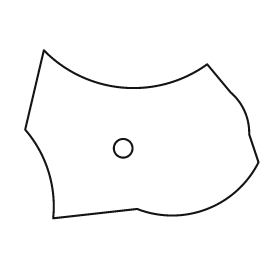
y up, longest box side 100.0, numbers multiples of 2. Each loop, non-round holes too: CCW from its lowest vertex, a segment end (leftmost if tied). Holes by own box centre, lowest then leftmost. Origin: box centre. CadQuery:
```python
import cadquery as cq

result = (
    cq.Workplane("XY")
    .moveTo(-38.0, -36.0)
    .lineTo(-2.0, -32.0)
    .threePointArc((28.0, -32.0), (50.0, -12.0))
    .lineTo(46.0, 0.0)
    .threePointArc((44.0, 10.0), (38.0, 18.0))
    .lineTo(28.0, 30.0)
    .threePointArc((-8.0, 20.0), (-42.0, 36.0))
    .lineTo(-50.0, 2.0)
    .threePointArc((-40.0, -16.0), (-38.0, -36.0))
    .close()
    .moveTo(-8.0, -6.0)
    .circle(4.0)
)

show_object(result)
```